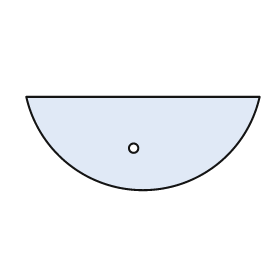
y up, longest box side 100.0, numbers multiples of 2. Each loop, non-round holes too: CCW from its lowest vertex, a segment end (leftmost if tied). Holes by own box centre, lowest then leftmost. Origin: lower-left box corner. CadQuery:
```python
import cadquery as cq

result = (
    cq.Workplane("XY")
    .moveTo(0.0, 40.0)
    .threePointArc((50.0, 0.0), (100.0, 40.0))
    .close()
    .moveTo(46.0, 18.0)
    .circle(2.0)
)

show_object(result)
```